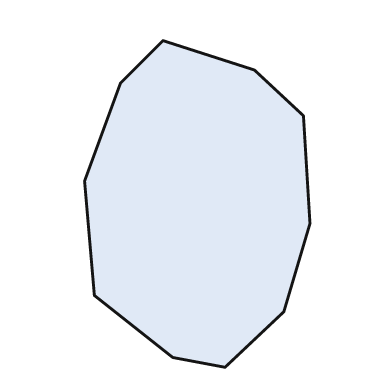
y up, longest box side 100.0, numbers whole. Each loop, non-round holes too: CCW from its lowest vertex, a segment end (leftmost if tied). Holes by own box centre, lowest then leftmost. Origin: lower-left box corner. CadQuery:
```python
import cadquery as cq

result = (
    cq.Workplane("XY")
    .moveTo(43.0, 0.0)
    .lineTo(61.0, 17.0)
    .lineTo(69.0, 44.0)
    .lineTo(67.0, 77.0)
    .lineTo(52.0, 91.0)
    .lineTo(24.0, 100.0)
    .lineTo(11.0, 87.0)
    .lineTo(0.0, 57.0)
    .lineTo(3.0, 22.0)
    .lineTo(27.0, 3.0)
    .close()
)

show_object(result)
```